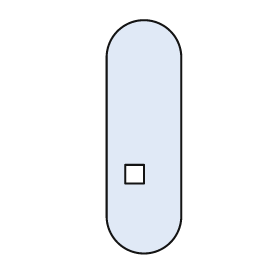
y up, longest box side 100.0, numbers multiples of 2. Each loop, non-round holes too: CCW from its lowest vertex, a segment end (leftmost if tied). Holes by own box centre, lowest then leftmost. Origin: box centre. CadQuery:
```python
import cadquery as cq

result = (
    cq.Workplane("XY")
    .moveTo(-16.0, -34.0)
    .threePointArc((0.0, -50.0), (16.0, -34.0))
    .lineTo(16.0, 34.0)
    .threePointArc((0.0, 50.0), (-16.0, 34.0))
    .close()
    .moveTo(-8.0, -20.0)
    .lineTo(0.0, -20.0)
    .lineTo(0.0, -12.0)
    .lineTo(-8.0, -12.0)
    .close()
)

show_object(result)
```